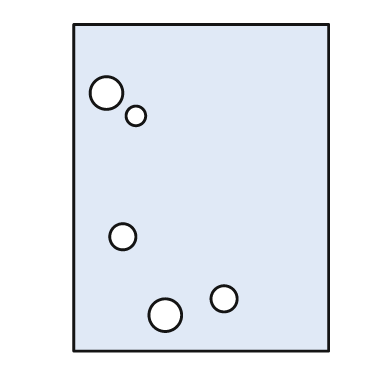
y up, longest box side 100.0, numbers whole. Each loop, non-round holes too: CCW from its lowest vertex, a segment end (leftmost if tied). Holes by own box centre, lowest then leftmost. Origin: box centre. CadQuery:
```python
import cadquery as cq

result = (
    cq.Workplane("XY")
    .moveTo(-39.0, -50.0)
    .lineTo(39.0, -50.0)
    .lineTo(39.0, 50.0)
    .lineTo(-39.0, 50.0)
    .close()
    .moveTo(-11.0, -39.0)
    .circle(5.0)
    .moveTo(7.0, -34.0)
    .circle(4.0)
    .moveTo(-24.0, -15.0)
    .circle(4.0)
    .moveTo(-20.0, 22.0)
    .circle(3.0)
    .moveTo(-29.0, 29.0)
    .circle(5.0)
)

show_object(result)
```